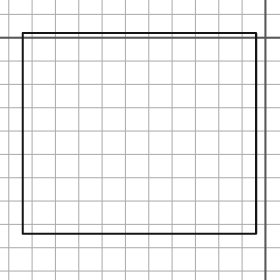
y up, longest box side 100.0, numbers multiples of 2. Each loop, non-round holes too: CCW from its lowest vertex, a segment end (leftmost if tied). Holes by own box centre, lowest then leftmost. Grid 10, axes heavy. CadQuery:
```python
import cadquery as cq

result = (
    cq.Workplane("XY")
    .moveTo(-104.0, -84.0)
    .lineTo(-4.0, -84.0)
    .lineTo(-4.0, 2.0)
    .lineTo(-104.0, 2.0)
    .close()
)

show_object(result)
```